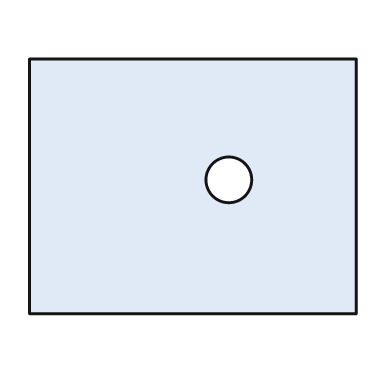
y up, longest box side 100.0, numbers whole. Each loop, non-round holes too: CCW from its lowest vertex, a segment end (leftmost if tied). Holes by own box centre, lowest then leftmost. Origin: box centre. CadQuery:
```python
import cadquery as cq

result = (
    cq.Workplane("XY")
    .moveTo(-50.0, -39.0)
    .lineTo(50.0, -39.0)
    .lineTo(50.0, 39.0)
    .lineTo(-50.0, 39.0)
    .close()
    .moveTo(11.0, 2.0)
    .circle(7.0)
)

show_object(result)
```